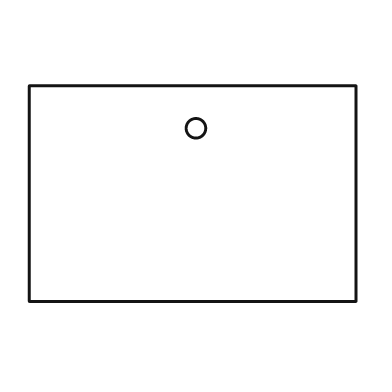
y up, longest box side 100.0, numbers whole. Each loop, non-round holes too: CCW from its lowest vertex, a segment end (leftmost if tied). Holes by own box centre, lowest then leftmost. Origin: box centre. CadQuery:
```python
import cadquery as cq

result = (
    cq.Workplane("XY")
    .moveTo(-50.0, -33.0)
    .lineTo(50.0, -33.0)
    .lineTo(50.0, 33.0)
    .lineTo(-50.0, 33.0)
    .close()
    .moveTo(1.0, 20.0)
    .circle(3.0)
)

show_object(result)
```